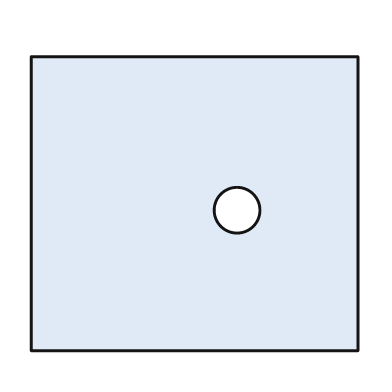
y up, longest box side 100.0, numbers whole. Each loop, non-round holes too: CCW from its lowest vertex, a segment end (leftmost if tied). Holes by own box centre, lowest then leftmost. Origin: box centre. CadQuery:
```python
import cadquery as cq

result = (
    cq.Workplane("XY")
    .moveTo(-50.0, -45.0)
    .lineTo(50.0, -45.0)
    .lineTo(50.0, 45.0)
    .lineTo(-50.0, 45.0)
    .close()
    .moveTo(13.0, -2.0)
    .circle(7.0)
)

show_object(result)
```